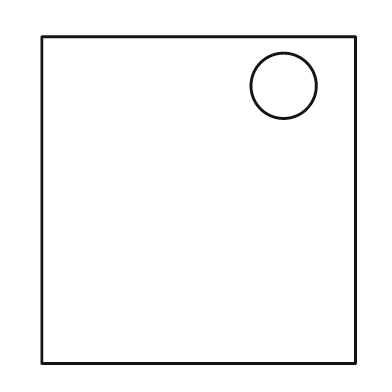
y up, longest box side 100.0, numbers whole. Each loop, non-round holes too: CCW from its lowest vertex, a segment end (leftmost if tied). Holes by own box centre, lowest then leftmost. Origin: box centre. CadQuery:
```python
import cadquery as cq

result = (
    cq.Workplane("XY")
    .moveTo(-48.0, -50.0)
    .lineTo(48.0, -50.0)
    .lineTo(48.0, 50.0)
    .lineTo(-48.0, 50.0)
    .close()
    .moveTo(26.0, 35.0)
    .circle(10.0)
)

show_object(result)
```